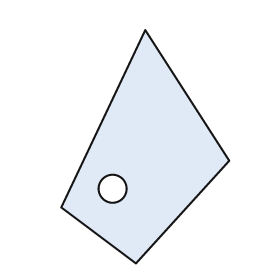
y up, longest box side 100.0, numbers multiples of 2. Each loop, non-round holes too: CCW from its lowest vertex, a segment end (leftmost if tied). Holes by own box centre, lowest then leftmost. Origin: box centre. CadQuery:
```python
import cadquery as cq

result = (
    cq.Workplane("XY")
    .moveTo(-4.0, -50.0)
    .lineTo(36.0, -6.0)
    .lineTo(0.0, 50.0)
    .lineTo(-36.0, -26.0)
    .close()
    .moveTo(-14.0, -18.0)
    .circle(6.0)
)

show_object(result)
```